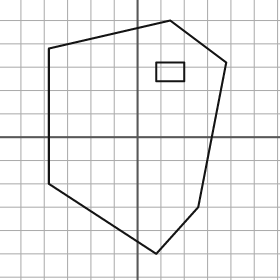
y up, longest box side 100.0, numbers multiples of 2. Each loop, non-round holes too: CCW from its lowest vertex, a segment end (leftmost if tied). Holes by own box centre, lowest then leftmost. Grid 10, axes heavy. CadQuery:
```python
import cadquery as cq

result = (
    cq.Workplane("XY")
    .moveTo(8.0, -50.0)
    .lineTo(26.0, -30.0)
    .lineTo(38.0, 32.0)
    .lineTo(14.0, 50.0)
    .lineTo(-38.0, 38.0)
    .lineTo(-38.0, -20.0)
    .close()
    .moveTo(8.0, 24.0)
    .lineTo(20.0, 24.0)
    .lineTo(20.0, 32.0)
    .lineTo(8.0, 32.0)
    .close()
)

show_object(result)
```